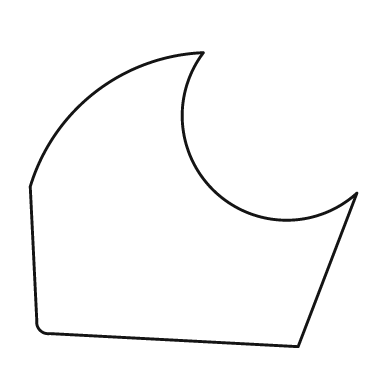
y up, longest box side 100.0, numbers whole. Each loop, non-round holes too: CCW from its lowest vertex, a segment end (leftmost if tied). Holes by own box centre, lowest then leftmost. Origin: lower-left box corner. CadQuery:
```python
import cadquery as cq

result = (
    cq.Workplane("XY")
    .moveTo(82.0, 0.0)
    .lineTo(100.0, 47.0)
    .threePointArc((57.0, 47.0), (53.0, 90.0))
    .threePointArc((20.0, 78.0), (0.0, 49.0))
    .lineTo(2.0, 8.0)
    .threePointArc((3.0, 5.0), (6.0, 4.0))
    .close()
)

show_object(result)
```